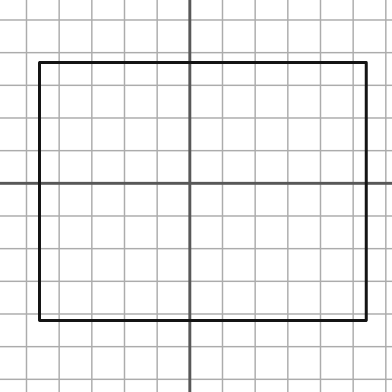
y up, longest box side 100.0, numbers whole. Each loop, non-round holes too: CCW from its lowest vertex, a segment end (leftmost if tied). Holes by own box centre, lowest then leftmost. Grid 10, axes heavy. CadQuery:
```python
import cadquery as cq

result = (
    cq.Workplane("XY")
    .moveTo(-46.0, -42.0)
    .lineTo(54.0, -42.0)
    .lineTo(54.0, 37.0)
    .lineTo(-46.0, 37.0)
    .close()
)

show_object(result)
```